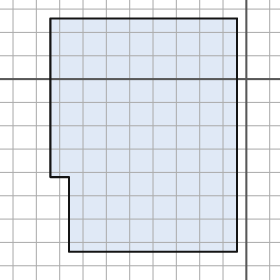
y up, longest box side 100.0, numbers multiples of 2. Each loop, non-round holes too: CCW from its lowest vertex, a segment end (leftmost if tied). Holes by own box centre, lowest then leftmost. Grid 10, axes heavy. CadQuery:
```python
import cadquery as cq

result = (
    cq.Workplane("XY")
    .moveTo(-76.0, -74.0)
    .lineTo(-4.0, -74.0)
    .lineTo(-4.0, 26.0)
    .lineTo(-84.0, 26.0)
    .lineTo(-84.0, -42.0)
    .lineTo(-76.0, -42.0)
    .close()
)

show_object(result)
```